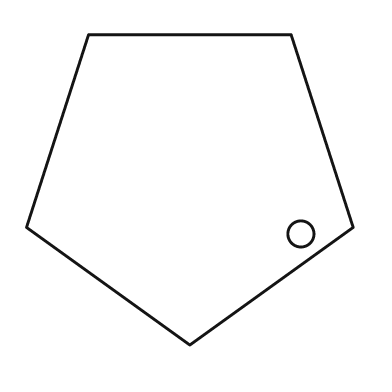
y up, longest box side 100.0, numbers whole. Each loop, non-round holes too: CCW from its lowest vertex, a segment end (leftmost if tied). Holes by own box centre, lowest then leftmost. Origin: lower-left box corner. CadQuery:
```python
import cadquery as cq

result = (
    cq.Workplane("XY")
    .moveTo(50.0, 0.0)
    .lineTo(100.0, 36.0)
    .lineTo(81.0, 95.0)
    .lineTo(19.0, 95.0)
    .lineTo(0.0, 36.0)
    .close()
    .moveTo(84.0, 34.0)
    .circle(4.0)
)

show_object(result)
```